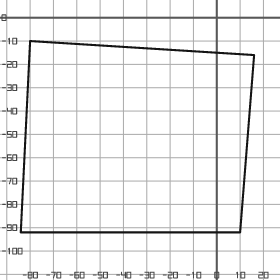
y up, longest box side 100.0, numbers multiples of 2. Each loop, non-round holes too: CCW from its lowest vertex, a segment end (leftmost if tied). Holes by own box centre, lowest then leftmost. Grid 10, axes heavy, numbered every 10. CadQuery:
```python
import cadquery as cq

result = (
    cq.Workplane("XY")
    .moveTo(-84.0, -92.0)
    .lineTo(10.0, -92.0)
    .lineTo(16.0, -16.0)
    .lineTo(-80.0, -10.0)
    .close()
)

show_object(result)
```